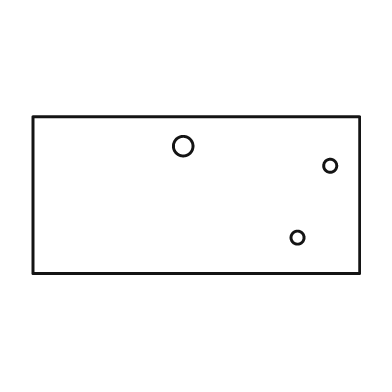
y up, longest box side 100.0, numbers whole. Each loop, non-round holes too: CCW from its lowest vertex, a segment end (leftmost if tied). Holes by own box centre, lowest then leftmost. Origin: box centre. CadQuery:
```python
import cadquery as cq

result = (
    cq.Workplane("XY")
    .moveTo(-50.0, -24.0)
    .lineTo(50.0, -24.0)
    .lineTo(50.0, 24.0)
    .lineTo(-50.0, 24.0)
    .close()
    .moveTo(31.0, -13.0)
    .circle(2.0)
    .moveTo(41.0, 9.0)
    .circle(2.0)
    .moveTo(-4.0, 15.0)
    .circle(3.0)
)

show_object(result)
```